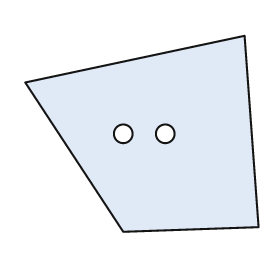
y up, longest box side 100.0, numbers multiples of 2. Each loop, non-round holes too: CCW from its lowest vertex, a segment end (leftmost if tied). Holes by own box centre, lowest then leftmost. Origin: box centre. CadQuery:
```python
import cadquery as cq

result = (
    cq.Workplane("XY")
    .moveTo(-8.0, -42.0)
    .lineTo(50.0, -40.0)
    .lineTo(44.0, 42.0)
    .lineTo(-50.0, 22.0)
    .close()
    .moveTo(-8.0, 0.0)
    .circle(4.0)
    .moveTo(10.0, 0.0)
    .circle(4.0)
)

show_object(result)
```